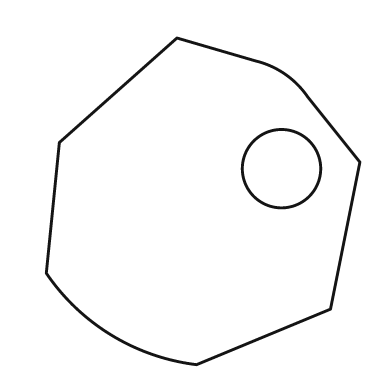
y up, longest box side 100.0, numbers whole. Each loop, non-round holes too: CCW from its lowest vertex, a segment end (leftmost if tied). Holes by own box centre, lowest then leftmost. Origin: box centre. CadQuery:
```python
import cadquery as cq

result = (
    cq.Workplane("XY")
    .moveTo(-2.0, -50.0)
    .lineTo(39.0, -33.0)
    .lineTo(48.0, 12.0)
    .lineTo(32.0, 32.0)
    .threePointArc((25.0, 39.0), (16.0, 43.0))
    .lineTo(-8.0, 50.0)
    .lineTo(-44.0, 18.0)
    .lineTo(-48.0, -22.0)
    .threePointArc((-28.0, -41.0), (-2.0, -50.0))
    .close()
    .moveTo(24.0, 10.0)
    .circle(12.0)
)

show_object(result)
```